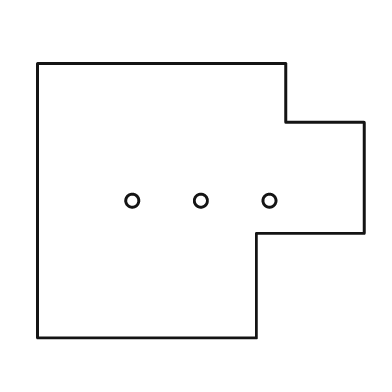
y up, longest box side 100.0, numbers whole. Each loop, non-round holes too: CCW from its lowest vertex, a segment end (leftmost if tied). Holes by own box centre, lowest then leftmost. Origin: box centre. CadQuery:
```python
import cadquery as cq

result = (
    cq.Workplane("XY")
    .moveTo(-50.0, -42.0)
    .lineTo(17.0, -42.0)
    .lineTo(17.0, -10.0)
    .lineTo(50.0, -10.0)
    .lineTo(50.0, 24.0)
    .lineTo(26.0, 24.0)
    .lineTo(26.0, 42.0)
    .lineTo(-50.0, 42.0)
    .close()
    .moveTo(-21.0, 0.0)
    .circle(2.0)
    .moveTo(0.0, 0.0)
    .circle(2.0)
    .moveTo(21.0, 0.0)
    .circle(2.0)
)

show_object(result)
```